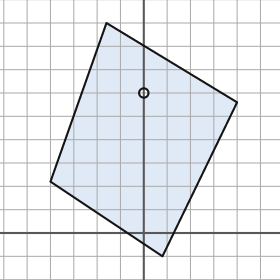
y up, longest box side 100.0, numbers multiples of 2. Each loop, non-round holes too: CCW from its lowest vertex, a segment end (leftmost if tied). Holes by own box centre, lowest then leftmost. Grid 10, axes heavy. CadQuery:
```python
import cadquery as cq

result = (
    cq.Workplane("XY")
    .moveTo(8.0, -10.0)
    .lineTo(40.0, 56.0)
    .lineTo(-16.0, 90.0)
    .lineTo(-40.0, 22.0)
    .close()
    .moveTo(0.0, 60.0)
    .circle(2.0)
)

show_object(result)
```